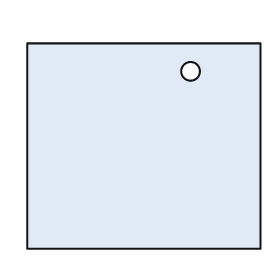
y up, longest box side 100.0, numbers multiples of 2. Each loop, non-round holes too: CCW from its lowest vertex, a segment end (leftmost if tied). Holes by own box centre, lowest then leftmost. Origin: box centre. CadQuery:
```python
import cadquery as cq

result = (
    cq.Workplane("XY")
    .moveTo(-50.0, -44.0)
    .lineTo(50.0, -44.0)
    .lineTo(50.0, 44.0)
    .lineTo(-50.0, 44.0)
    .close()
    .moveTo(20.0, 32.0)
    .circle(4.0)
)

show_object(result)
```